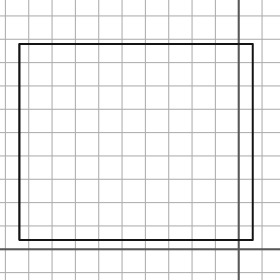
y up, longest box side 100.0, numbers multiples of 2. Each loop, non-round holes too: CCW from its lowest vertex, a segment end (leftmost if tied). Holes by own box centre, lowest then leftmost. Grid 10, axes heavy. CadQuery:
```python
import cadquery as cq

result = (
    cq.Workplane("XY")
    .moveTo(-94.0, 4.0)
    .lineTo(6.0, 4.0)
    .lineTo(6.0, 88.0)
    .lineTo(-94.0, 88.0)
    .close()
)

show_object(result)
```